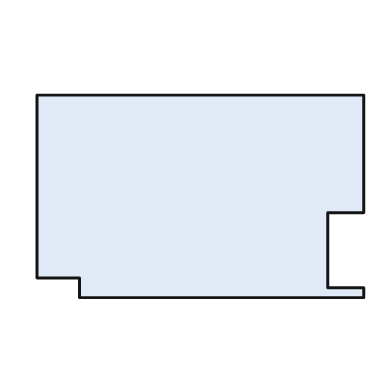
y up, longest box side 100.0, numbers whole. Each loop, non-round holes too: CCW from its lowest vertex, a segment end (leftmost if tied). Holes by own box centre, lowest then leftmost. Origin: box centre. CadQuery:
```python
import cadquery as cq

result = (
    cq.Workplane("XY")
    .moveTo(-37.0, -31.0)
    .lineTo(50.0, -31.0)
    .lineTo(50.0, -28.0)
    .lineTo(39.0, -28.0)
    .lineTo(39.0, -5.0)
    .lineTo(50.0, -5.0)
    .lineTo(50.0, 31.0)
    .lineTo(-50.0, 31.0)
    .lineTo(-50.0, -25.0)
    .lineTo(-37.0, -25.0)
    .close()
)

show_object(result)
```